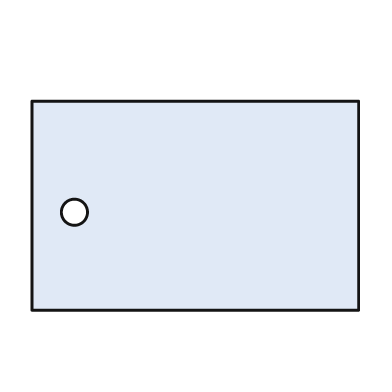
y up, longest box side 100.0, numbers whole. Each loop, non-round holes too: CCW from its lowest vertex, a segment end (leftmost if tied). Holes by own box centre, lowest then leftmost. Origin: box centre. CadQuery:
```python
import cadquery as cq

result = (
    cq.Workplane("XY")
    .moveTo(-50.0, -32.0)
    .lineTo(50.0, -32.0)
    .lineTo(50.0, 32.0)
    .lineTo(-50.0, 32.0)
    .close()
    .moveTo(-37.0, -2.0)
    .circle(4.0)
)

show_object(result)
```